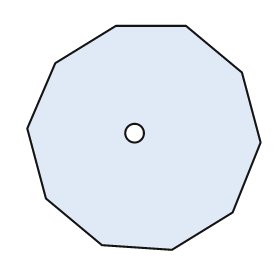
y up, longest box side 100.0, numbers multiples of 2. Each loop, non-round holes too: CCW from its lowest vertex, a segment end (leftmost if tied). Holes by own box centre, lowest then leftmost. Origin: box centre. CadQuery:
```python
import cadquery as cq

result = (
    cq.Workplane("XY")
    .moveTo(12.0, -48.0)
    .lineTo(38.0, -32.0)
    .lineTo(50.0, -2.0)
    .lineTo(42.0, 28.0)
    .lineTo(18.0, 48.0)
    .lineTo(-12.0, 48.0)
    .lineTo(-38.0, 32.0)
    .lineTo(-50.0, 4.0)
    .lineTo(-42.0, -26.0)
    .lineTo(-18.0, -46.0)
    .close()
    .moveTo(-4.0, 2.0)
    .circle(4.0)
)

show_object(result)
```